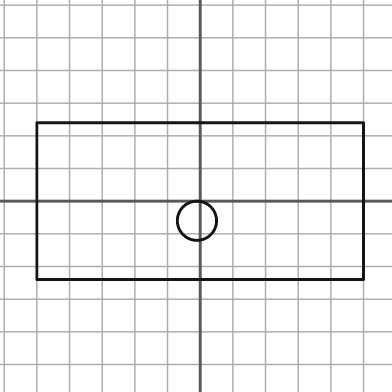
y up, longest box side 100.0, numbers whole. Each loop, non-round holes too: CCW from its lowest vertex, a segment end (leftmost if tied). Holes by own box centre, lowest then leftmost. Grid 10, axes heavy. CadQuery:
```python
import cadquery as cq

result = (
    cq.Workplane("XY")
    .moveTo(-50.0, -24.0)
    .lineTo(50.0, -24.0)
    .lineTo(50.0, 24.0)
    .lineTo(-50.0, 24.0)
    .close()
    .moveTo(-1.0, -6.0)
    .circle(6.0)
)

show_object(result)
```